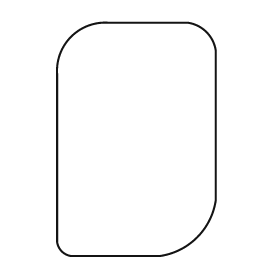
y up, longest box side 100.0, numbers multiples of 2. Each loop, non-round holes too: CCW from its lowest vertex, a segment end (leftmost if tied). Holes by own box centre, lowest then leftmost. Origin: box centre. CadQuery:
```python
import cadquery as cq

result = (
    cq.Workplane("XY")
    .moveTo(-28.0, -50.0)
    .lineTo(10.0, -50.0)
    .threePointArc((26.0, -42.0), (34.0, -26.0))
    .lineTo(34.0, 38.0)
    .threePointArc((30.0, 46.0), (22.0, 50.0))
    .lineTo(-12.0, 50.0)
    .threePointArc((-28.0, 44.0), (-34.0, 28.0))
    .lineTo(-34.0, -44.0)
    .threePointArc((-32.0, -48.0), (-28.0, -50.0))
    .close()
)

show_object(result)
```